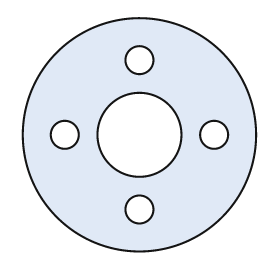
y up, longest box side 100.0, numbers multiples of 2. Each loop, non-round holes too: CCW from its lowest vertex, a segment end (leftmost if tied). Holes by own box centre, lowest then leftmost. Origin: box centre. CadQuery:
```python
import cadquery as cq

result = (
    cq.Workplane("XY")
    .moveTo(0.0, 0.0)
    .circle(50.0)
    .moveTo(0.0, -32.0)
    .circle(6.0)
    .moveTo(-32.0, 0.0)
    .circle(6.0)
    .moveTo(0.0, 0.0)
    .circle(18.0)
    .moveTo(32.0, 0.0)
    .circle(6.0)
    .moveTo(0.0, 32.0)
    .circle(6.0)
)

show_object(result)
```